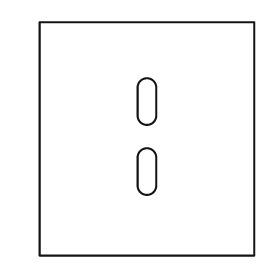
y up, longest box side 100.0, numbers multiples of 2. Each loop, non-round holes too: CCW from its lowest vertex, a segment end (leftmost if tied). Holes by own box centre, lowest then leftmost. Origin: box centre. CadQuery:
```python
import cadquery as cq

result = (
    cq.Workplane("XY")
    .moveTo(-46.0, -50.0)
    .lineTo(46.0, -50.0)
    .lineTo(46.0, 50.0)
    .lineTo(-46.0, 50.0)
    .close()
    .moveTo(-4.0, -20.0)
    .threePointArc((0.0, -24.0), (4.0, -20.0))
    .lineTo(4.0, -8.0)
    .threePointArc((0.0, -4.0), (-4.0, -8.0))
    .close()
    .moveTo(-4.0, 10.0)
    .threePointArc((0.0, 6.0), (4.0, 10.0))
    .lineTo(4.0, 22.0)
    .threePointArc((0.0, 26.0), (-4.0, 22.0))
    .close()
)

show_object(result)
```